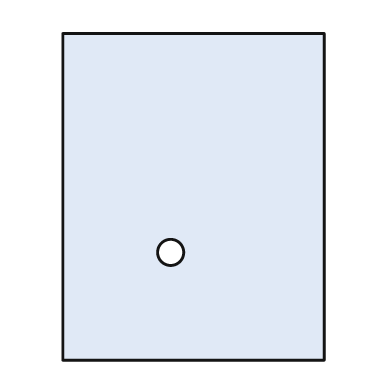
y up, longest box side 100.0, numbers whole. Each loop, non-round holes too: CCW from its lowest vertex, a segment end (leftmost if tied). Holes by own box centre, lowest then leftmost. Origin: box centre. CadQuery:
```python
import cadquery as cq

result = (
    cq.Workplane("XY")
    .moveTo(-40.0, -50.0)
    .lineTo(40.0, -50.0)
    .lineTo(40.0, 50.0)
    .lineTo(-40.0, 50.0)
    .close()
    .moveTo(-7.0, -17.0)
    .circle(4.0)
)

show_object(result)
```